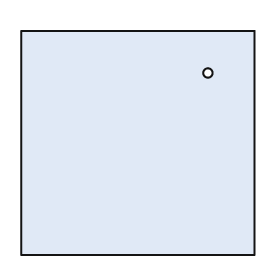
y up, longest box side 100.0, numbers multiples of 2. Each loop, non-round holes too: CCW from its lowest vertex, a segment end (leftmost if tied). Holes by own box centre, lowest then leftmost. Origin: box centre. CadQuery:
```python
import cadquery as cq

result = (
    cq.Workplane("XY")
    .moveTo(-50.0, -48.0)
    .lineTo(50.0, -48.0)
    .lineTo(50.0, 48.0)
    .lineTo(-50.0, 48.0)
    .close()
    .moveTo(30.0, 30.0)
    .circle(2.0)
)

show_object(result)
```